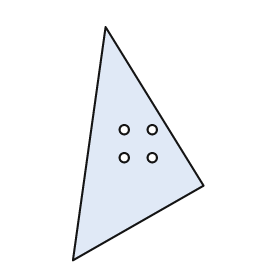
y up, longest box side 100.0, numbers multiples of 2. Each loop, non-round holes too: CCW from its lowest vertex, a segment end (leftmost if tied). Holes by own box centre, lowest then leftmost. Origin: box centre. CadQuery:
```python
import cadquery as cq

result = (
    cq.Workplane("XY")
    .moveTo(-28.0, -50.0)
    .lineTo(28.0, -18.0)
    .lineTo(-14.0, 50.0)
    .close()
    .moveTo(-6.0, -6.0)
    .circle(2.0)
    .moveTo(6.0, -6.0)
    .circle(2.0)
    .moveTo(-6.0, 6.0)
    .circle(2.0)
    .moveTo(6.0, 6.0)
    .circle(2.0)
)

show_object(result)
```